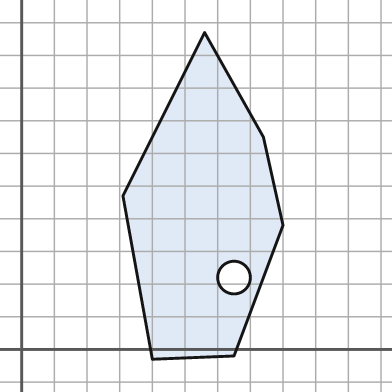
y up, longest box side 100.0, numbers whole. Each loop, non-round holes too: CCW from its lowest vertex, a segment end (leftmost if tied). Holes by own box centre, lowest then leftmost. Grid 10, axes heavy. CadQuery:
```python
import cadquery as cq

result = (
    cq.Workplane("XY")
    .moveTo(40.0, -3.0)
    .lineTo(65.0, -2.0)
    .lineTo(80.0, 38.0)
    .lineTo(74.0, 65.0)
    .lineTo(56.0, 97.0)
    .lineTo(31.0, 47.0)
    .close()
    .moveTo(65.0, 22.0)
    .circle(5.0)
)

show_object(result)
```